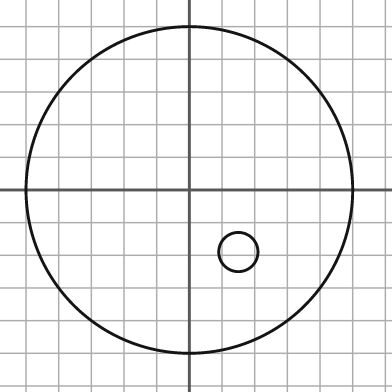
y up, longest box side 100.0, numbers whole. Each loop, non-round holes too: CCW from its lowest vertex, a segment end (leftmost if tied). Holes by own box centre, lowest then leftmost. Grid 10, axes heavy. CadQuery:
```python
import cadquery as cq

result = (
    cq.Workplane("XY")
    .moveTo(0.0, 0.0)
    .circle(50.0)
    .moveTo(15.0, -19.0)
    .circle(6.0)
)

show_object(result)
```